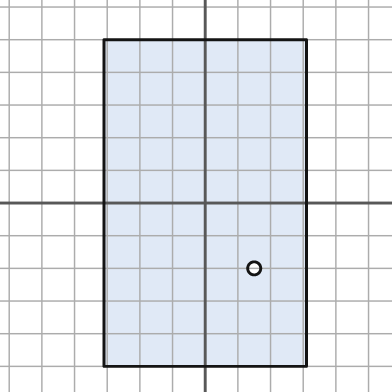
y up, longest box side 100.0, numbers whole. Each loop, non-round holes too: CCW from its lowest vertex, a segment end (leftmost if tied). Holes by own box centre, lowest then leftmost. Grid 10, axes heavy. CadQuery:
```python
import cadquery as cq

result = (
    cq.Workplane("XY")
    .moveTo(-31.0, -50.0)
    .lineTo(31.0, -50.0)
    .lineTo(31.0, 50.0)
    .lineTo(-31.0, 50.0)
    .close()
    .moveTo(15.0, -20.0)
    .circle(2.0)
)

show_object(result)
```